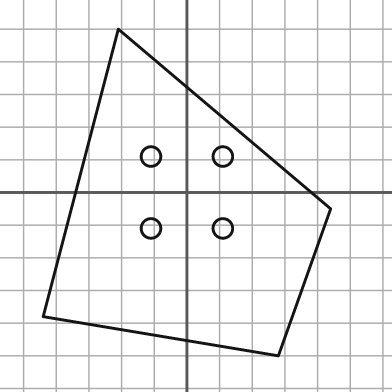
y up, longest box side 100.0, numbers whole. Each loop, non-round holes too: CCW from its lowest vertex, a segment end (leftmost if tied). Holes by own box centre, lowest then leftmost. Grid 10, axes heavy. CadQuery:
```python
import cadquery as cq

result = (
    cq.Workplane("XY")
    .moveTo(28.0, -50.0)
    .lineTo(44.0, -5.0)
    .lineTo(-21.0, 50.0)
    .lineTo(-44.0, -38.0)
    .close()
    .moveTo(-11.0, -11.0)
    .circle(3.0)
    .moveTo(11.0, -11.0)
    .circle(3.0)
    .moveTo(-11.0, 11.0)
    .circle(3.0)
    .moveTo(11.0, 11.0)
    .circle(3.0)
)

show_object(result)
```